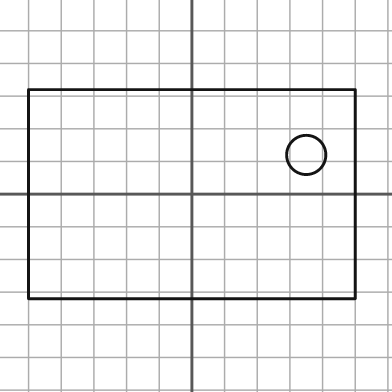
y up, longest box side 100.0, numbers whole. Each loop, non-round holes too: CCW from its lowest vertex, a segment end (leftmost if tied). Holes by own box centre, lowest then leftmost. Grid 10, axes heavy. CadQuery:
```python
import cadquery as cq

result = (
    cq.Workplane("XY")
    .moveTo(-50.0, -32.0)
    .lineTo(50.0, -32.0)
    .lineTo(50.0, 32.0)
    .lineTo(-50.0, 32.0)
    .close()
    .moveTo(35.0, 12.0)
    .circle(6.0)
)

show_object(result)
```